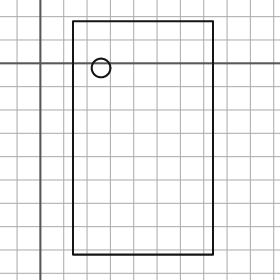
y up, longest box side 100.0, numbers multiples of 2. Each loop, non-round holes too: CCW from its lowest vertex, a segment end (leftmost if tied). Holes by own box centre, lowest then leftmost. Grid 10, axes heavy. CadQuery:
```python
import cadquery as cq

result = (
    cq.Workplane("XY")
    .moveTo(14.0, -82.0)
    .lineTo(74.0, -82.0)
    .lineTo(74.0, 18.0)
    .lineTo(14.0, 18.0)
    .close()
    .moveTo(26.0, -2.0)
    .circle(4.0)
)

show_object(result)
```